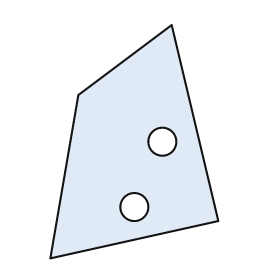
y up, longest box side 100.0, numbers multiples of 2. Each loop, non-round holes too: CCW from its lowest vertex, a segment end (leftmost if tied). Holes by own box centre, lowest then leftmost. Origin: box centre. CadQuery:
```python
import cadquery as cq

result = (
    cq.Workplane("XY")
    .moveTo(-36.0, -50.0)
    .lineTo(36.0, -34.0)
    .lineTo(16.0, 50.0)
    .lineTo(-24.0, 20.0)
    .close()
    .moveTo(0.0, -28.0)
    .circle(6.0)
    .moveTo(12.0, 0.0)
    .circle(6.0)
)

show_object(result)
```